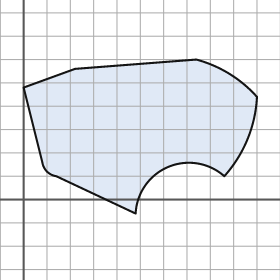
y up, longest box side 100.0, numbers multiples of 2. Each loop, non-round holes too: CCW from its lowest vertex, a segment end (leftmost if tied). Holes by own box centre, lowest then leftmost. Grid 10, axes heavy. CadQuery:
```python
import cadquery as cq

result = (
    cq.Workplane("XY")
    .moveTo(48.0, -6.0)
    .threePointArc((62.0, 14.0), (86.0, 10.0))
    .threePointArc((96.0, 26.0), (100.0, 44.0))
    .threePointArc((88.0, 54.0), (74.0, 60.0))
    .lineTo(22.0, 56.0)
    .lineTo(0.0, 48.0)
    .lineTo(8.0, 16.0)
    .threePointArc((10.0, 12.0), (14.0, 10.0))
    .close()
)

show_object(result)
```